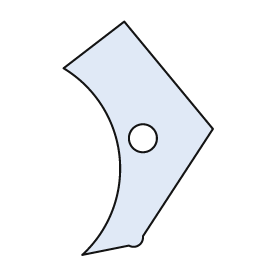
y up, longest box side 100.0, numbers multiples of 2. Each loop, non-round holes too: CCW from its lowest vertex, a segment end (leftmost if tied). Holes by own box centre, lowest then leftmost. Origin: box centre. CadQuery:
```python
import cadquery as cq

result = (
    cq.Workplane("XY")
    .moveTo(-24.0, -50.0)
    .lineTo(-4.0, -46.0)
    .threePointArc((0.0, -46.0), (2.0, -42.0))
    .lineTo(32.0, 4.0)
    .lineTo(-6.0, 50.0)
    .lineTo(-32.0, 30.0)
    .threePointArc((-8.0, -8.0), (-24.0, -50.0))
    .close()
    .moveTo(2.0, 0.0)
    .circle(6.0)
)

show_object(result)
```